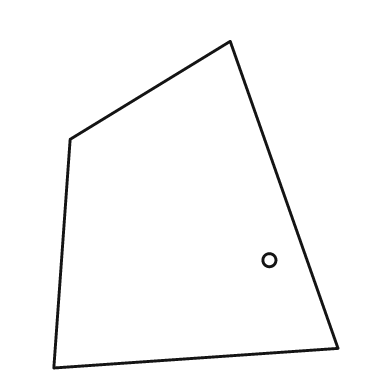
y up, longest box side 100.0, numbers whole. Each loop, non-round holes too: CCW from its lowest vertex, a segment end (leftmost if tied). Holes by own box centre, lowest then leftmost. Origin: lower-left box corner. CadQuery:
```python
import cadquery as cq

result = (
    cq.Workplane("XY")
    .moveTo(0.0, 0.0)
    .lineTo(87.0, 6.0)
    .lineTo(54.0, 100.0)
    .lineTo(5.0, 70.0)
    .close()
    .moveTo(66.0, 33.0)
    .circle(2.0)
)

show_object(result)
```